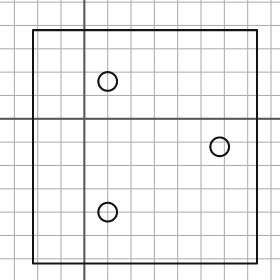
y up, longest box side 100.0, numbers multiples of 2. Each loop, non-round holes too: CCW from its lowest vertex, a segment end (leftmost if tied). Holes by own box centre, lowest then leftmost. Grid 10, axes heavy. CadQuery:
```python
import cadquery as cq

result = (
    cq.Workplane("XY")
    .moveTo(-22.0, -62.0)
    .lineTo(74.0, -62.0)
    .lineTo(74.0, 38.0)
    .lineTo(-22.0, 38.0)
    .close()
    .moveTo(10.0, -40.0)
    .circle(4.0)
    .moveTo(58.0, -12.0)
    .circle(4.0)
    .moveTo(10.0, 16.0)
    .circle(4.0)
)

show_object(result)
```